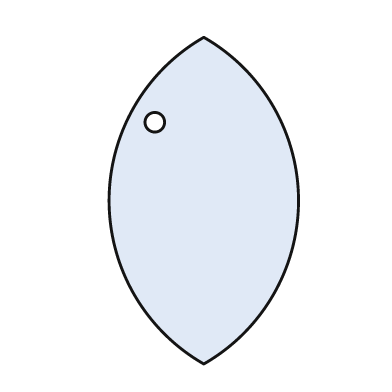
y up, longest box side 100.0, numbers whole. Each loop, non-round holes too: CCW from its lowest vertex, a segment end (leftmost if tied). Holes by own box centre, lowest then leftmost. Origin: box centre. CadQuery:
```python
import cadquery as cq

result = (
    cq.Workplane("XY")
    .moveTo(0.0, -50.0)
    .threePointArc((29.0, 0.0), (0.0, 50.0))
    .threePointArc((-29.0, 0.0), (0.0, -50.0))
    .close()
    .moveTo(-15.0, 24.0)
    .circle(3.0)
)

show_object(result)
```